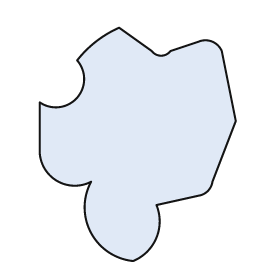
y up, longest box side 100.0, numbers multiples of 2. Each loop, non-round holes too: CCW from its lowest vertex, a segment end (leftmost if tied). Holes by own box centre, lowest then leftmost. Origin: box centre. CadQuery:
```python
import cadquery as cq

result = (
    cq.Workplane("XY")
    .moveTo(-2.0, -50.0)
    .threePointArc((8.0, -40.0), (8.0, -26.0))
    .lineTo(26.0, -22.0)
    .threePointArc((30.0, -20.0), (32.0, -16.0))
    .lineTo(42.0, 10.0)
    .lineTo(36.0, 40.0)
    .threePointArc((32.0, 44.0), (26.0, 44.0))
    .lineTo(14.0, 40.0)
    .threePointArc((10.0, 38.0), (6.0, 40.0))
    .lineTo(-8.0, 50.0)
    .threePointArc((-18.0, 44.0), (-26.0, 36.0))
    .threePointArc((-26.0, 20.0), (-42.0, 18.0))
    .lineTo(-42.0, -4.0)
    .threePointArc((-34.0, -16.0), (-20.0, -16.0))
    .threePointArc((-20.0, -38.0), (-2.0, -50.0))
    .close()
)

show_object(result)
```